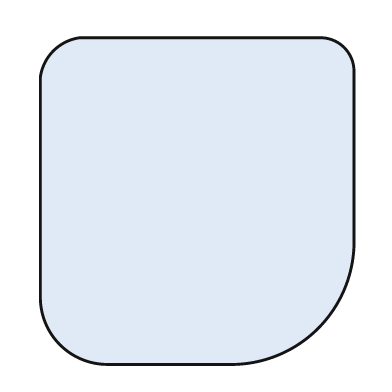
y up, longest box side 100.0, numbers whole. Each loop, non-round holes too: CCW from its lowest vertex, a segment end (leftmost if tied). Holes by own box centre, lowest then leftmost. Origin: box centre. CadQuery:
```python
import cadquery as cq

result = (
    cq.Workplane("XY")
    .moveTo(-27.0, -50.0)
    .lineTo(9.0, -50.0)
    .threePointArc((37.0, -39.0), (48.0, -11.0))
    .lineTo(48.0, 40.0)
    .threePointArc((45.0, 47.0), (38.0, 50.0))
    .lineTo(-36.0, 50.0)
    .threePointArc((-44.0, 46.0), (-48.0, 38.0))
    .lineTo(-48.0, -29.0)
    .threePointArc((-42.0, -44.0), (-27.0, -50.0))
    .close()
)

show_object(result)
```